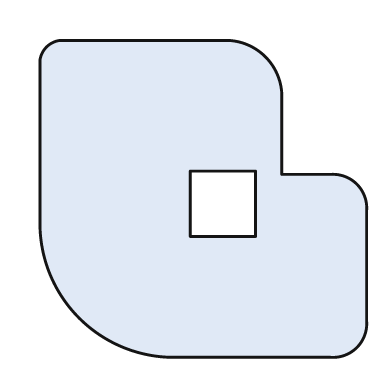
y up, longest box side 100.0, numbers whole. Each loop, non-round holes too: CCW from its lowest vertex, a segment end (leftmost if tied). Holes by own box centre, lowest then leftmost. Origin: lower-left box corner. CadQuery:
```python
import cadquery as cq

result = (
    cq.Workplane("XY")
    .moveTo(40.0, 0.0)
    .lineTo(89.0, 0.0)
    .threePointArc((97.0, 3.0), (100.0, 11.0))
    .lineTo(100.0, 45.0)
    .threePointArc((97.0, 53.0), (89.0, 56.0))
    .lineTo(74.0, 56.0)
    .lineTo(74.0, 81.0)
    .threePointArc((69.0, 92.0), (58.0, 97.0))
    .lineTo(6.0, 97.0)
    .threePointArc((2.0, 95.0), (0.0, 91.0))
    .lineTo(0.0, 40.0)
    .threePointArc((12.0, 12.0), (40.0, 0.0))
    .close()
    .moveTo(46.0, 37.0)
    .lineTo(66.0, 37.0)
    .lineTo(66.0, 57.0)
    .lineTo(46.0, 57.0)
    .close()
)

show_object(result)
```